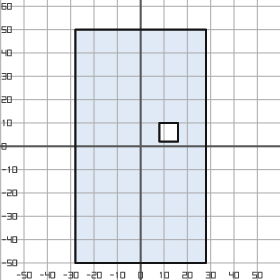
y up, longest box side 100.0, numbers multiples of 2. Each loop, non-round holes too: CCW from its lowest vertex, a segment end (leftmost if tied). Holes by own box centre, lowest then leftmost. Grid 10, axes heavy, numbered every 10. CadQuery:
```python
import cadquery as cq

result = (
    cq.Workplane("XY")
    .moveTo(-28.0, -50.0)
    .lineTo(28.0, -50.0)
    .lineTo(28.0, 50.0)
    .lineTo(-28.0, 50.0)
    .close()
    .moveTo(8.0, 2.0)
    .lineTo(16.0, 2.0)
    .lineTo(16.0, 10.0)
    .lineTo(8.0, 10.0)
    .close()
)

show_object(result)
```